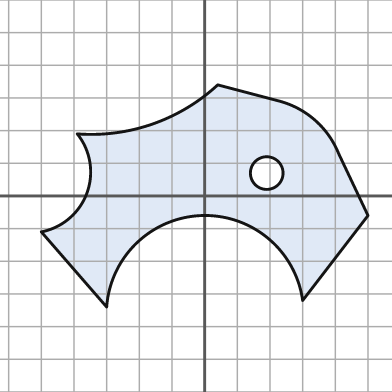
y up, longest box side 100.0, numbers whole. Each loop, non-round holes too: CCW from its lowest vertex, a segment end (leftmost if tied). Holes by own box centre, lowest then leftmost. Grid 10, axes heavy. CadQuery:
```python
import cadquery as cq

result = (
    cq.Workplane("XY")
    .moveTo(-30.0, -34.0)
    .threePointArc((-1.0, -6.0), (30.0, -32.0))
    .lineTo(50.0, -6.0)
    .lineTo(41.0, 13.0)
    .threePointArc((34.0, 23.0), (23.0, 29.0))
    .lineTo(4.0, 34.0)
    .threePointArc((-16.0, 22.0), (-39.0, 19.0))
    .threePointArc((-36.0, 1.0), (-50.0, -11.0))
    .close()
    .moveTo(19.0, 7.0)
    .circle(5.0)
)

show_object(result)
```